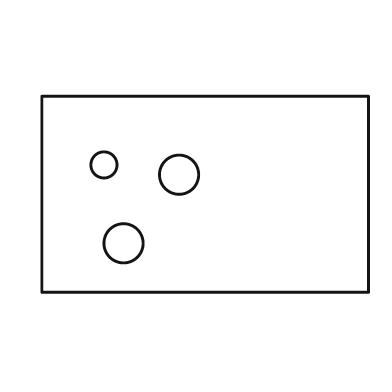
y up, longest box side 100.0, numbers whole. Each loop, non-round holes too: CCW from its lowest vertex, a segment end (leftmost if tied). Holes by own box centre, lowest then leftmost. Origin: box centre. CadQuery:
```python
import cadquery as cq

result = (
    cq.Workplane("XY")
    .moveTo(-50.0, -30.0)
    .lineTo(50.0, -30.0)
    .lineTo(50.0, 30.0)
    .lineTo(-50.0, 30.0)
    .close()
    .moveTo(-25.0, -15.0)
    .circle(6.0)
    .moveTo(-8.0, 6.0)
    .circle(6.0)
    .moveTo(-31.0, 9.0)
    .circle(4.0)
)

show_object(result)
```